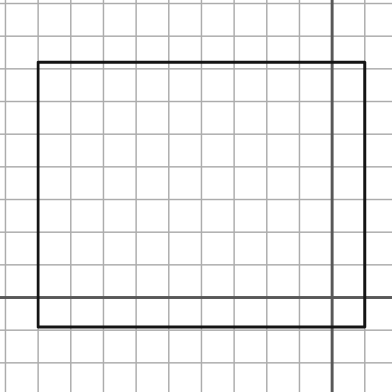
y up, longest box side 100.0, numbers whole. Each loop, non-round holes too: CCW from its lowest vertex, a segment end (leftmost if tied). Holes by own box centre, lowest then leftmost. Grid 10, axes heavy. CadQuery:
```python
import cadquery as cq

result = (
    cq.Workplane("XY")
    .moveTo(-90.0, -9.0)
    .lineTo(10.0, -9.0)
    .lineTo(10.0, 72.0)
    .lineTo(-90.0, 72.0)
    .close()
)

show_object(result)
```